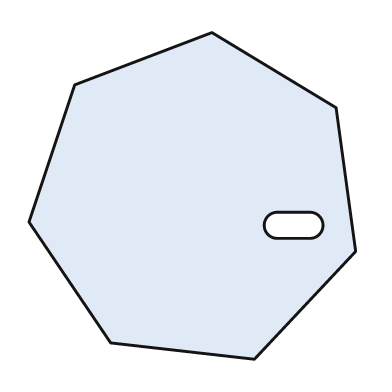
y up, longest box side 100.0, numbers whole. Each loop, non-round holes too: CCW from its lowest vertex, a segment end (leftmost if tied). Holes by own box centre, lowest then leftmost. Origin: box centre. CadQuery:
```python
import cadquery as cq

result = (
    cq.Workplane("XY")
    .moveTo(19.0, -50.0)
    .lineTo(50.0, -17.0)
    .lineTo(44.0, 27.0)
    .lineTo(6.0, 50.0)
    .lineTo(-36.0, 34.0)
    .lineTo(-50.0, -8.0)
    .lineTo(-25.0, -45.0)
    .close()
    .moveTo(26.0, -13.0)
    .lineTo(36.0, -13.0)
    .threePointArc((40.0, -9.0), (36.0, -5.0))
    .lineTo(26.0, -5.0)
    .threePointArc((22.0, -9.0), (26.0, -13.0))
    .close()
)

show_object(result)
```